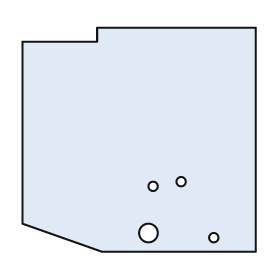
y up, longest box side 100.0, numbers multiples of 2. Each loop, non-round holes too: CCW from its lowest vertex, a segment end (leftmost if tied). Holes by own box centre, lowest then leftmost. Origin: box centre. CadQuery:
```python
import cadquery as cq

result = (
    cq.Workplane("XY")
    .moveTo(-16.0, -48.0)
    .lineTo(50.0, -48.0)
    .lineTo(50.0, 48.0)
    .lineTo(-18.0, 48.0)
    .lineTo(-18.0, 42.0)
    .lineTo(-50.0, 42.0)
    .lineTo(-50.0, -36.0)
    .close()
    .moveTo(32.0, -42.0)
    .circle(2.0)
    .moveTo(4.0, -40.0)
    .circle(4.0)
    .moveTo(6.0, -20.0)
    .circle(2.0)
    .moveTo(18.0, -18.0)
    .circle(2.0)
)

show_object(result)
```